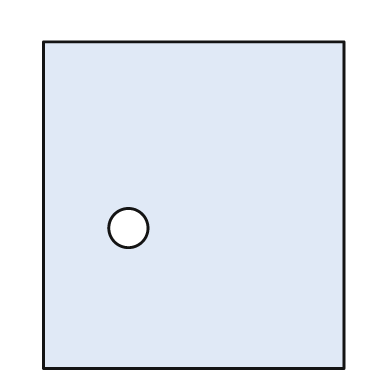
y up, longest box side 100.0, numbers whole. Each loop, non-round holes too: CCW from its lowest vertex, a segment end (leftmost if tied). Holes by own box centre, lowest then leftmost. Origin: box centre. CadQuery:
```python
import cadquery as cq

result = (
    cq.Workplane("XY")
    .moveTo(-46.0, -50.0)
    .lineTo(46.0, -50.0)
    .lineTo(46.0, 50.0)
    .lineTo(-46.0, 50.0)
    .close()
    .moveTo(-20.0, -7.0)
    .circle(6.0)
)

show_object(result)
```